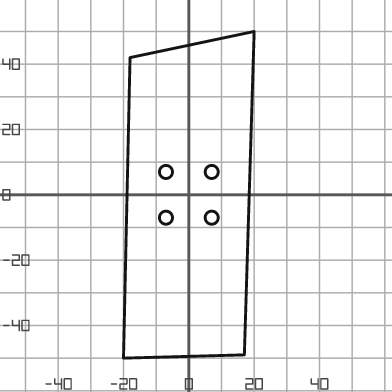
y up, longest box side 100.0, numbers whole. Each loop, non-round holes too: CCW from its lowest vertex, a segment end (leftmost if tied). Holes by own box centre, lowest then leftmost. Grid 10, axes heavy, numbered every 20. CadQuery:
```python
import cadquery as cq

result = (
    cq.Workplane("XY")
    .moveTo(-20.0, -50.0)
    .lineTo(17.0, -49.0)
    .lineTo(20.0, 50.0)
    .lineTo(-18.0, 42.0)
    .close()
    .moveTo(-7.0, -7.0)
    .circle(2.0)
    .moveTo(7.0, -7.0)
    .circle(2.0)
    .moveTo(-7.0, 7.0)
    .circle(2.0)
    .moveTo(7.0, 7.0)
    .circle(2.0)
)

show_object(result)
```